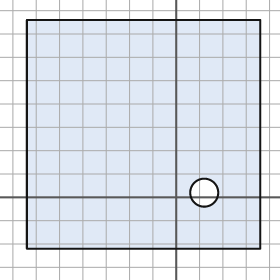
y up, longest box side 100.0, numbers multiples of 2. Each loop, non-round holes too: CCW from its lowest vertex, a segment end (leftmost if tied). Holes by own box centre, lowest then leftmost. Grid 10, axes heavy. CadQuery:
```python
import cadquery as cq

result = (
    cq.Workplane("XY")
    .moveTo(-64.0, -22.0)
    .lineTo(36.0, -22.0)
    .lineTo(36.0, 76.0)
    .lineTo(-64.0, 76.0)
    .close()
    .moveTo(12.0, 2.0)
    .circle(6.0)
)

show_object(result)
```